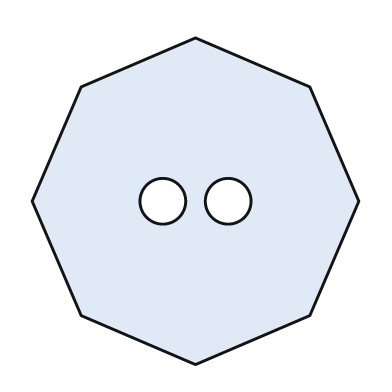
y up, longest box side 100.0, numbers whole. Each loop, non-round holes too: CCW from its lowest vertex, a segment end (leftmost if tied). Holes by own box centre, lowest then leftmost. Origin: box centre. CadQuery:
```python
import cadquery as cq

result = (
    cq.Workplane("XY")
    .moveTo(0.0, -50.0)
    .lineTo(35.0, -35.0)
    .lineTo(50.0, 0.0)
    .lineTo(35.0, 35.0)
    .lineTo(0.0, 50.0)
    .lineTo(-35.0, 35.0)
    .lineTo(-50.0, 0.0)
    .lineTo(-35.0, -35.0)
    .close()
    .moveTo(-10.0, 0.0)
    .circle(7.0)
    .moveTo(10.0, 0.0)
    .circle(7.0)
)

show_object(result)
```